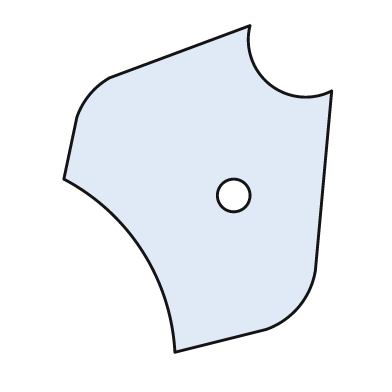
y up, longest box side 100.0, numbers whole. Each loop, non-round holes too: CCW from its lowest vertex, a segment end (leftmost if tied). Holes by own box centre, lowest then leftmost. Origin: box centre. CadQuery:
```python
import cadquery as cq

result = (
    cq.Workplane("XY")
    .moveTo(-7.0, -50.0)
    .lineTo(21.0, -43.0)
    .threePointArc((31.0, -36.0), (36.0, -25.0))
    .lineTo(41.0, 30.0)
    .threePointArc((22.0, 32.0), (16.0, 50.0))
    .lineTo(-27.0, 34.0)
    .threePointArc((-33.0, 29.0), (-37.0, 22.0))
    .lineTo(-41.0, 3.0)
    .threePointArc((-17.0, -19.0), (-7.0, -50.0))
    .close()
    .moveTo(11.0, -2.0)
    .circle(5.0)
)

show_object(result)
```